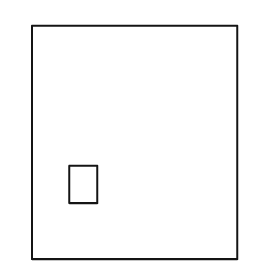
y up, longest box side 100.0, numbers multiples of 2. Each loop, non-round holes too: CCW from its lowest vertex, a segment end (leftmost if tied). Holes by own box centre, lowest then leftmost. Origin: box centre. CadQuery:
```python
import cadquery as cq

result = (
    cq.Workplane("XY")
    .moveTo(-44.0, -50.0)
    .lineTo(44.0, -50.0)
    .lineTo(44.0, 50.0)
    .lineTo(-44.0, 50.0)
    .close()
    .moveTo(-28.0, -26.0)
    .lineTo(-16.0, -26.0)
    .lineTo(-16.0, -10.0)
    .lineTo(-28.0, -10.0)
    .close()
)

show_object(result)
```